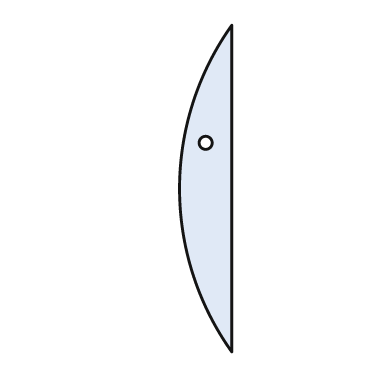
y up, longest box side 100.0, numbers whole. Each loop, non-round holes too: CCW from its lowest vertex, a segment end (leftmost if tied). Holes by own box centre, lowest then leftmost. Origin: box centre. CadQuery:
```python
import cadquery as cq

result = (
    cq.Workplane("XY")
    .moveTo(8.0, -50.0)
    .lineTo(8.0, 50.0)
    .threePointArc((-8.0, 0.0), (8.0, -50.0))
    .close()
    .moveTo(0.0, 14.0)
    .circle(2.0)
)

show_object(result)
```